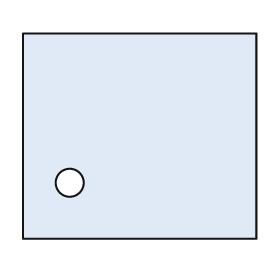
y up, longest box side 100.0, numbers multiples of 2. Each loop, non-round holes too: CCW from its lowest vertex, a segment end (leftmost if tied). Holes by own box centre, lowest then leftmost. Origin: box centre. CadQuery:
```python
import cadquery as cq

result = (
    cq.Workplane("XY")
    .moveTo(-50.0, -44.0)
    .lineTo(50.0, -44.0)
    .lineTo(50.0, 44.0)
    .lineTo(-50.0, 44.0)
    .close()
    .moveTo(-30.0, -20.0)
    .circle(6.0)
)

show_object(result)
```